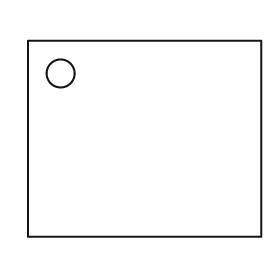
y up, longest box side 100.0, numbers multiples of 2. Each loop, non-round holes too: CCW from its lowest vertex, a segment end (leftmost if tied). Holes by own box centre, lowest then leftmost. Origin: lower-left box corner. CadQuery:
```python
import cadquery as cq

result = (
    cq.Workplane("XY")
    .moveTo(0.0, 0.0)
    .lineTo(100.0, 0.0)
    .lineTo(100.0, 84.0)
    .lineTo(0.0, 84.0)
    .close()
    .moveTo(14.0, 70.0)
    .circle(6.0)
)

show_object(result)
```